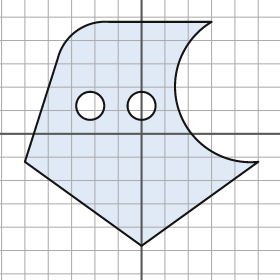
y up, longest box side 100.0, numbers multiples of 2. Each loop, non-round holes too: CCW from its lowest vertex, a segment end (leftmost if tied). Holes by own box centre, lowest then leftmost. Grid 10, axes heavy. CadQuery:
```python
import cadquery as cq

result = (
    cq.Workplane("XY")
    .moveTo(0.0, -48.0)
    .lineTo(50.0, -12.0)
    .threePointArc((16.0, 10.0), (30.0, 48.0))
    .lineTo(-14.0, 48.0)
    .threePointArc((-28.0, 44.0), (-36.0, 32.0))
    .lineTo(-50.0, -12.0)
    .close()
    .moveTo(-22.0, 12.0)
    .circle(6.0)
    .moveTo(0.0, 12.0)
    .circle(6.0)
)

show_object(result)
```